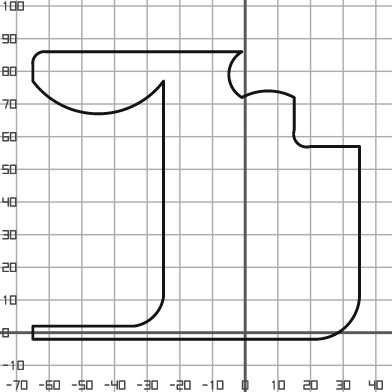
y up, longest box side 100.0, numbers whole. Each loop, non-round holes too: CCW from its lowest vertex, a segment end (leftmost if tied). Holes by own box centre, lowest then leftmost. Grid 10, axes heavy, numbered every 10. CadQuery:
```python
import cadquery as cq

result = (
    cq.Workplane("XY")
    .moveTo(-65.0, -2.0)
    .lineTo(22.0, -2.0)
    .threePointArc((31.0, 2.0), (35.0, 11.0))
    .lineTo(35.0, 57.0)
    .lineTo(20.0, 57.0)
    .threePointArc((16.0, 58.0), (15.0, 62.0))
    .lineTo(15.0, 72.0)
    .threePointArc((7.0, 74.0), (-1.0, 72.0))
    .threePointArc((-5.0, 79.0), (-1.0, 86.0))
    .lineTo(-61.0, 86.0)
    .threePointArc((-64.0, 85.0), (-65.0, 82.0))
    .lineTo(-65.0, 77.0)
    .threePointArc((-45.0, 67.0), (-25.0, 77.0))
    .lineTo(-25.0, 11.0)
    .threePointArc((-28.0, 5.0), (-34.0, 2.0))
    .lineTo(-65.0, 2.0)
    .close()
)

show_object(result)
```